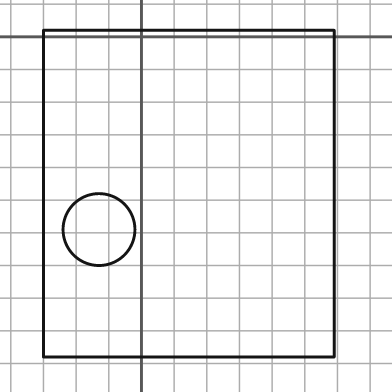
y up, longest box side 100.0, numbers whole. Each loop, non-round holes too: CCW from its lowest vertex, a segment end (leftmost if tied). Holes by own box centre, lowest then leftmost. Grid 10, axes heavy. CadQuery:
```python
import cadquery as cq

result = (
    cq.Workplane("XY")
    .moveTo(-30.0, -98.0)
    .lineTo(59.0, -98.0)
    .lineTo(59.0, 2.0)
    .lineTo(-30.0, 2.0)
    .close()
    .moveTo(-13.0, -59.0)
    .circle(11.0)
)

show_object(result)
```